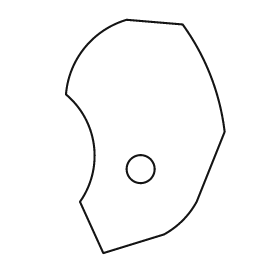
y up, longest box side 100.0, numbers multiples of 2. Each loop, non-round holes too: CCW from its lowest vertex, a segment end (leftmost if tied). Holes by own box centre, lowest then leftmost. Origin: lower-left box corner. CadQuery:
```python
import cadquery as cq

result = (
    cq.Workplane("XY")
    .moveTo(16.0, 0.0)
    .lineTo(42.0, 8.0)
    .threePointArc((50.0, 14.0), (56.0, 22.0))
    .lineTo(68.0, 52.0)
    .threePointArc((62.0, 76.0), (50.0, 98.0))
    .lineTo(26.0, 100.0)
    .threePointArc((8.0, 88.0), (0.0, 68.0))
    .threePointArc((12.0, 46.0), (6.0, 22.0))
    .close()
    .moveTo(32.0, 36.0)
    .circle(6.0)
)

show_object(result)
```